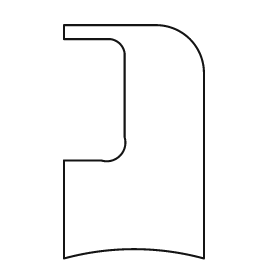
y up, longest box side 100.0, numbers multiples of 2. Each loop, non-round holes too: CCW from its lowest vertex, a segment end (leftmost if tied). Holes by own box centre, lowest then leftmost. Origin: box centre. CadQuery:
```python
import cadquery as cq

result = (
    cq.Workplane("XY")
    .moveTo(-30.0, -50.0)
    .threePointArc((0.0, -46.0), (30.0, -50.0))
    .lineTo(30.0, 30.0)
    .threePointArc((24.0, 44.0), (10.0, 50.0))
    .lineTo(-30.0, 50.0)
    .lineTo(-30.0, 44.0)
    .lineTo(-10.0, 44.0)
    .threePointArc((-6.0, 42.0), (-4.0, 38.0))
    .lineTo(-4.0, 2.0)
    .threePointArc((-6.0, -6.0), (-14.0, -8.0))
    .lineTo(-30.0, -8.0)
    .close()
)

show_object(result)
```